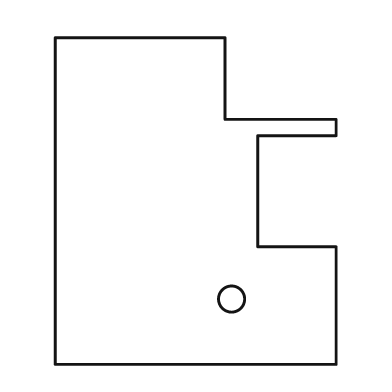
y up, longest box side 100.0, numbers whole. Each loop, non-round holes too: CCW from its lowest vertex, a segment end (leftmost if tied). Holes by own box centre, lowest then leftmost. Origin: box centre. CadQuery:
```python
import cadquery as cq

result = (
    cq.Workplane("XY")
    .moveTo(-43.0, -50.0)
    .lineTo(43.0, -50.0)
    .lineTo(43.0, -14.0)
    .lineTo(19.0, -14.0)
    .lineTo(19.0, 20.0)
    .lineTo(43.0, 20.0)
    .lineTo(43.0, 25.0)
    .lineTo(9.0, 25.0)
    .lineTo(9.0, 50.0)
    .lineTo(-43.0, 50.0)
    .close()
    .moveTo(11.0, -30.0)
    .circle(4.0)
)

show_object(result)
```